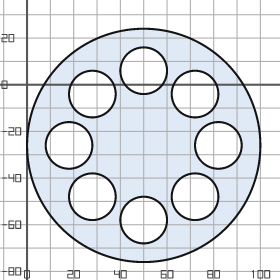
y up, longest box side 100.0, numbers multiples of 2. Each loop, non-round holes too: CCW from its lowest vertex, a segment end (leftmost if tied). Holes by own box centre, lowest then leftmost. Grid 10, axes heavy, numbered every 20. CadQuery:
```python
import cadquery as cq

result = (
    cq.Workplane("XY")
    .moveTo(50.0, -26.0)
    .circle(50.0)
    .moveTo(50.0, -58.0)
    .circle(10.0)
    .moveTo(28.0, -48.0)
    .circle(10.0)
    .moveTo(72.0, -48.0)
    .circle(10.0)
    .moveTo(18.0, -26.0)
    .circle(10.0)
    .moveTo(82.0, -26.0)
    .circle(10.0)
    .moveTo(28.0, -4.0)
    .circle(10.0)
    .moveTo(72.0, -4.0)
    .circle(10.0)
    .moveTo(50.0, 6.0)
    .circle(10.0)
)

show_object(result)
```